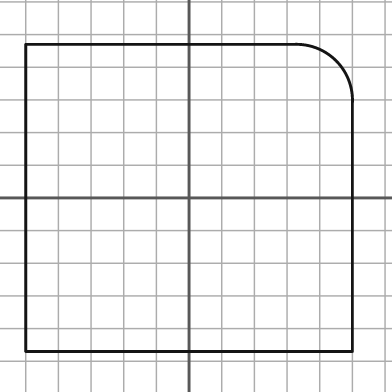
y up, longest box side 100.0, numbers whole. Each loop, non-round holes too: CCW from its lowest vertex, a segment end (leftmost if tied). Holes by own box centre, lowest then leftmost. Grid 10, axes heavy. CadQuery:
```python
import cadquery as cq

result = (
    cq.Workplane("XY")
    .moveTo(-50.0, -47.0)
    .lineTo(50.0, -47.0)
    .lineTo(50.0, 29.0)
    .threePointArc((45.0, 42.0), (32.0, 47.0))
    .lineTo(-50.0, 47.0)
    .close()
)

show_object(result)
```